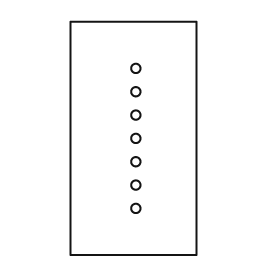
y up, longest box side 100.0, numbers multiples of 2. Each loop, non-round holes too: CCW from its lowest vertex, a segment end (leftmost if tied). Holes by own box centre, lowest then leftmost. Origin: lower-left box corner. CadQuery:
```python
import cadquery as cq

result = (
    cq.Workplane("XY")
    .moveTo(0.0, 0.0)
    .lineTo(54.0, 0.0)
    .lineTo(54.0, 100.0)
    .lineTo(0.0, 100.0)
    .close()
    .moveTo(28.0, 20.0)
    .circle(2.0)
    .moveTo(28.0, 30.0)
    .circle(2.0)
    .moveTo(28.0, 40.0)
    .circle(2.0)
    .moveTo(28.0, 50.0)
    .circle(2.0)
    .moveTo(28.0, 60.0)
    .circle(2.0)
    .moveTo(28.0, 70.0)
    .circle(2.0)
    .moveTo(28.0, 80.0)
    .circle(2.0)
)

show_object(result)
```